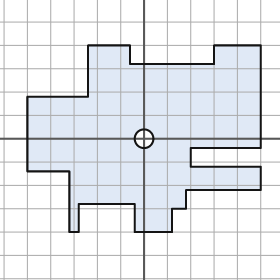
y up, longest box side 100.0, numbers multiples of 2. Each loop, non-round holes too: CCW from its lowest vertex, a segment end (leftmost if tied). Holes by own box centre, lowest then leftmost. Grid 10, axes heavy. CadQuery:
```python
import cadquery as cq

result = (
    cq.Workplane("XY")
    .moveTo(-32.0, -40.0)
    .lineTo(-28.0, -40.0)
    .lineTo(-28.0, -28.0)
    .lineTo(-4.0, -28.0)
    .lineTo(-4.0, -40.0)
    .lineTo(12.0, -40.0)
    .lineTo(12.0, -30.0)
    .lineTo(18.0, -30.0)
    .lineTo(18.0, -22.0)
    .lineTo(50.0, -22.0)
    .lineTo(50.0, -12.0)
    .lineTo(20.0, -12.0)
    .lineTo(20.0, -4.0)
    .lineTo(50.0, -4.0)
    .lineTo(50.0, 40.0)
    .lineTo(30.0, 40.0)
    .lineTo(30.0, 32.0)
    .lineTo(-6.0, 32.0)
    .lineTo(-6.0, 40.0)
    .lineTo(-24.0, 40.0)
    .lineTo(-24.0, 18.0)
    .lineTo(-50.0, 18.0)
    .lineTo(-50.0, -14.0)
    .lineTo(-32.0, -14.0)
    .close()
    .moveTo(0.0, 0.0)
    .circle(4.0)
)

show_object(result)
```